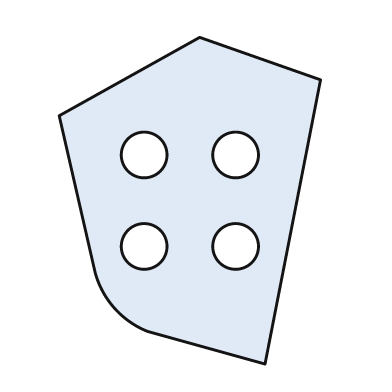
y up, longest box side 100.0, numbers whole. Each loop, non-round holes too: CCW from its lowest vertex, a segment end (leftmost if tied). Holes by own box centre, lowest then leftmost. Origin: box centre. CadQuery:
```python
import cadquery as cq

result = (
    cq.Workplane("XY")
    .moveTo(23.0, -50.0)
    .lineTo(40.0, 37.0)
    .lineTo(3.0, 50.0)
    .lineTo(-40.0, 26.0)
    .lineTo(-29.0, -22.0)
    .threePointArc((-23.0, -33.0), (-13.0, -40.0))
    .close()
    .moveTo(-14.0, -14.0)
    .circle(7.0)
    .moveTo(14.0, -14.0)
    .circle(7.0)
    .moveTo(-14.0, 14.0)
    .circle(7.0)
    .moveTo(14.0, 14.0)
    .circle(7.0)
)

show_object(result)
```